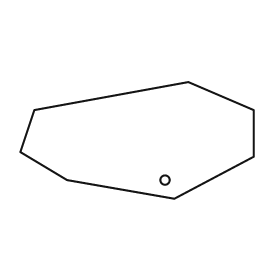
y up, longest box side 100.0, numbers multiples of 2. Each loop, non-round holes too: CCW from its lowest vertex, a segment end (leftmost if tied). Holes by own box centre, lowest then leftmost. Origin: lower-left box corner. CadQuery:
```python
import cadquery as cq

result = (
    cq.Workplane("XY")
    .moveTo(66.0, 0.0)
    .lineTo(100.0, 18.0)
    .lineTo(100.0, 38.0)
    .lineTo(72.0, 50.0)
    .lineTo(6.0, 38.0)
    .lineTo(0.0, 20.0)
    .lineTo(20.0, 8.0)
    .close()
    .moveTo(62.0, 8.0)
    .circle(2.0)
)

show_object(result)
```